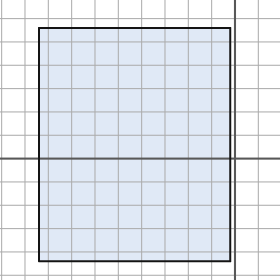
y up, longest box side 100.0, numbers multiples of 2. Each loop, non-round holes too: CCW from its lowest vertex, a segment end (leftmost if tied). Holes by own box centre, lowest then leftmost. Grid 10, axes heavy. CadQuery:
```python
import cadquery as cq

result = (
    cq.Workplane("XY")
    .moveTo(-84.0, -44.0)
    .lineTo(-2.0, -44.0)
    .lineTo(-2.0, 56.0)
    .lineTo(-84.0, 56.0)
    .close()
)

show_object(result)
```